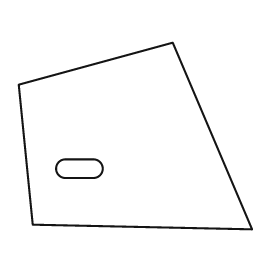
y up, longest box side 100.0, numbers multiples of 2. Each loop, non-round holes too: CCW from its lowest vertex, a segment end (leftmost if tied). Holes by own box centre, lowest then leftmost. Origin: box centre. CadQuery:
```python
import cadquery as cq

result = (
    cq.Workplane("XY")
    .moveTo(50.0, -40.0)
    .lineTo(16.0, 40.0)
    .lineTo(-50.0, 22.0)
    .lineTo(-44.0, -38.0)
    .close()
    .moveTo(-30.0, -18.0)
    .lineTo(-18.0, -18.0)
    .threePointArc((-14.0, -14.0), (-18.0, -10.0))
    .lineTo(-30.0, -10.0)
    .threePointArc((-34.0, -14.0), (-30.0, -18.0))
    .close()
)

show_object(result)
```